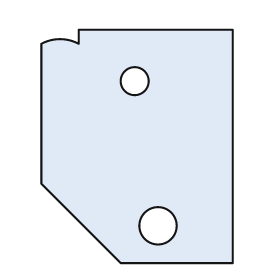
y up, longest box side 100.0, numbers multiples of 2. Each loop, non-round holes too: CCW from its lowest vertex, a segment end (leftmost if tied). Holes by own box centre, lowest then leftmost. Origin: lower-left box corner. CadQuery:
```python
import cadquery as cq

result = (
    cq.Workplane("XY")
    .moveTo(34.0, 0.0)
    .lineTo(82.0, 0.0)
    .lineTo(82.0, 100.0)
    .lineTo(16.0, 100.0)
    .lineTo(16.0, 94.0)
    .threePointArc((8.0, 96.0), (0.0, 94.0))
    .lineTo(0.0, 34.0)
    .close()
    .moveTo(50.0, 16.0)
    .circle(8.0)
    .moveTo(40.0, 78.0)
    .circle(6.0)
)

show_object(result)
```